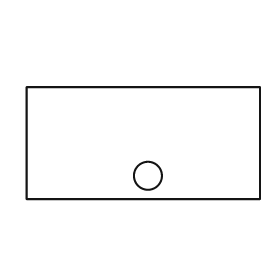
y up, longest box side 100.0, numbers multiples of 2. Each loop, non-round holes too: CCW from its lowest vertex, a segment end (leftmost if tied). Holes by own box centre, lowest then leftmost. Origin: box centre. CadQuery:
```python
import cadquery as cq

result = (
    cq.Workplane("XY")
    .moveTo(-50.0, -24.0)
    .lineTo(50.0, -24.0)
    .lineTo(50.0, 24.0)
    .lineTo(-50.0, 24.0)
    .close()
    .moveTo(2.0, -14.0)
    .circle(6.0)
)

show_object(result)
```